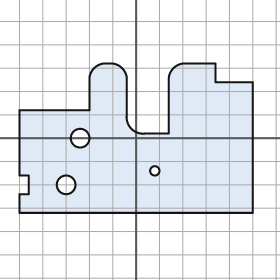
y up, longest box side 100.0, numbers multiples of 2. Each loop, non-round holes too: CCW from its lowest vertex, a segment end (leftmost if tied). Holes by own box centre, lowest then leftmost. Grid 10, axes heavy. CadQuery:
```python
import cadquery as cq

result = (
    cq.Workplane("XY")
    .moveTo(-50.0, -32.0)
    .lineTo(50.0, -32.0)
    .lineTo(50.0, 24.0)
    .lineTo(34.0, 24.0)
    .lineTo(34.0, 32.0)
    .lineTo(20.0, 32.0)
    .threePointArc((16.0, 30.0), (14.0, 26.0))
    .lineTo(14.0, 2.0)
    .lineTo(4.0, 2.0)
    .threePointArc((-2.0, 4.0), (-4.0, 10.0))
    .lineTo(-4.0, 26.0)
    .threePointArc((-6.0, 30.0), (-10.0, 32.0))
    .lineTo(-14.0, 32.0)
    .threePointArc((-18.0, 30.0), (-20.0, 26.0))
    .lineTo(-20.0, 12.0)
    .lineTo(-50.0, 12.0)
    .lineTo(-50.0, -16.0)
    .lineTo(-46.0, -16.0)
    .lineTo(-46.0, -24.0)
    .lineTo(-50.0, -24.0)
    .close()
    .moveTo(-30.0, -20.0)
    .circle(4.0)
    .moveTo(8.0, -14.0)
    .circle(2.0)
    .moveTo(-24.0, 0.0)
    .circle(4.0)
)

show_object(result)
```